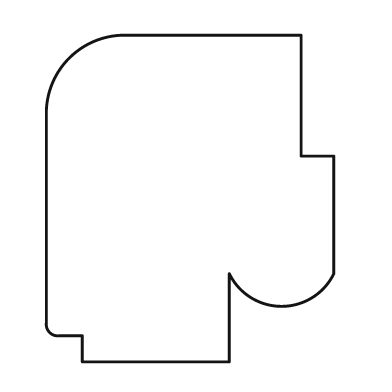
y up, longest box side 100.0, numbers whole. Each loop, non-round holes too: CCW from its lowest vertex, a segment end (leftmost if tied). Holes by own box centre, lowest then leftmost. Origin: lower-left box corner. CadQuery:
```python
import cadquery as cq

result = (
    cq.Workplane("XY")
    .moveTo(11.0, 0.0)
    .lineTo(56.0, 0.0)
    .lineTo(56.0, 27.0)
    .threePointArc((72.0, 17.0), (88.0, 27.0))
    .lineTo(88.0, 63.0)
    .lineTo(78.0, 63.0)
    .lineTo(78.0, 100.0)
    .lineTo(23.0, 100.0)
    .threePointArc((7.0, 93.0), (0.0, 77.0))
    .lineTo(0.0, 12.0)
    .threePointArc((1.0, 9.0), (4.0, 8.0))
    .lineTo(11.0, 8.0)
    .close()
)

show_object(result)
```